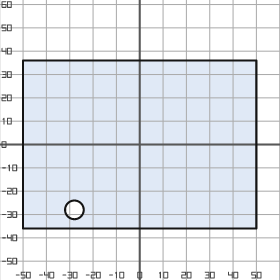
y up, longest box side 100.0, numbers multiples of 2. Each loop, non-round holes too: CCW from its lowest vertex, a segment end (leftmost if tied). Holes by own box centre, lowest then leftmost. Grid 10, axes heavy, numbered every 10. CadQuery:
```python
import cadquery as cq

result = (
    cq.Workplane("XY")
    .moveTo(-50.0, -36.0)
    .lineTo(50.0, -36.0)
    .lineTo(50.0, 36.0)
    .lineTo(-50.0, 36.0)
    .close()
    .moveTo(-28.0, -28.0)
    .circle(4.0)
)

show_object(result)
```